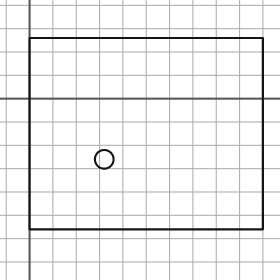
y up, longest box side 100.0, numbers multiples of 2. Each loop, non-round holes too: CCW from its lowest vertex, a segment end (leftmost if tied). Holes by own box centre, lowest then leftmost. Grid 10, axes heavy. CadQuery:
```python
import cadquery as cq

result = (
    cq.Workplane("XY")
    .moveTo(0.0, -56.0)
    .lineTo(100.0, -56.0)
    .lineTo(100.0, 26.0)
    .lineTo(0.0, 26.0)
    .close()
    .moveTo(32.0, -26.0)
    .circle(4.0)
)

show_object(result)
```